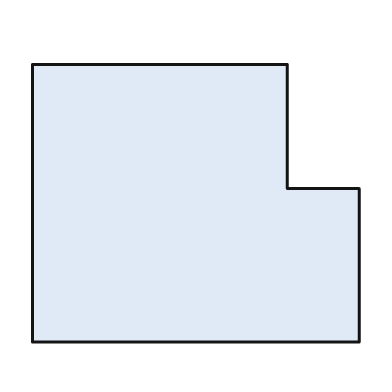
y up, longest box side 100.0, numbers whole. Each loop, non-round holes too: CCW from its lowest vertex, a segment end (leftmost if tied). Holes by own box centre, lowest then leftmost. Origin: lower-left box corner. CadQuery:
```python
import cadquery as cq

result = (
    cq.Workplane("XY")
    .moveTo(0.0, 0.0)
    .lineTo(100.0, 0.0)
    .lineTo(100.0, 47.0)
    .lineTo(78.0, 47.0)
    .lineTo(78.0, 85.0)
    .lineTo(0.0, 85.0)
    .close()
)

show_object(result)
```